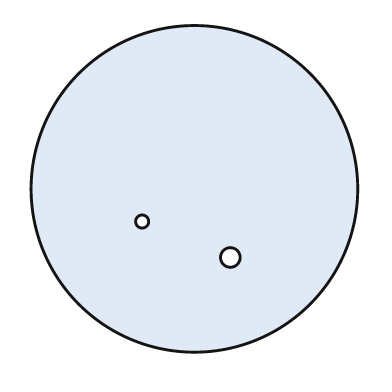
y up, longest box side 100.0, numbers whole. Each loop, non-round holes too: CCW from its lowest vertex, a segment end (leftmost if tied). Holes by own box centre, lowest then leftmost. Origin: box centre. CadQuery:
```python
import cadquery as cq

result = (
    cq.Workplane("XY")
    .moveTo(0.0, 0.0)
    .circle(50.0)
    .moveTo(11.0, -21.0)
    .circle(3.0)
    .moveTo(-16.0, -10.0)
    .circle(2.0)
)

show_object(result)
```